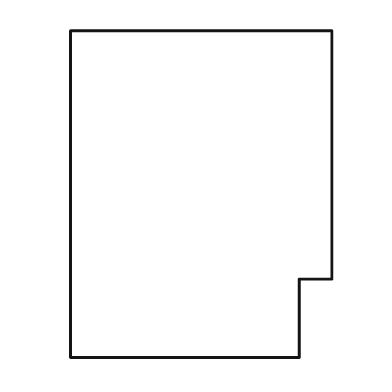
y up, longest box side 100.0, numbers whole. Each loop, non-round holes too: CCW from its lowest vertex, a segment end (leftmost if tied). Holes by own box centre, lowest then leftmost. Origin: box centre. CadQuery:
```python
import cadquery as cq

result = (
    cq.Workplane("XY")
    .moveTo(-40.0, -50.0)
    .lineTo(30.0, -50.0)
    .lineTo(30.0, -26.0)
    .lineTo(40.0, -26.0)
    .lineTo(40.0, 50.0)
    .lineTo(-40.0, 50.0)
    .close()
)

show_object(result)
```